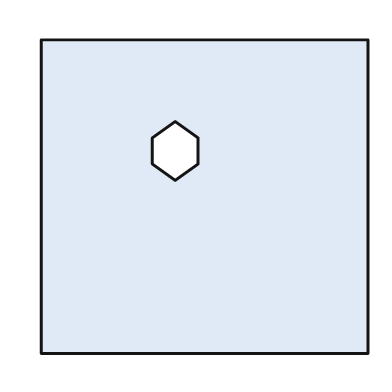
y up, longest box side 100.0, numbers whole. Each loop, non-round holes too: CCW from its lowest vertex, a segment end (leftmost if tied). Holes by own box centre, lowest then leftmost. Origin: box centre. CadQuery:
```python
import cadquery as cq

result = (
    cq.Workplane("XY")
    .moveTo(-50.0, -48.0)
    .lineTo(50.0, -48.0)
    .lineTo(50.0, 48.0)
    .lineTo(-50.0, 48.0)
    .close()
    .moveTo(-9.0, 5.0)
    .lineTo(-2.0, 10.0)
    .lineTo(-2.0, 18.0)
    .lineTo(-9.0, 23.0)
    .lineTo(-16.0, 18.0)
    .lineTo(-16.0, 10.0)
    .close()
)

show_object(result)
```